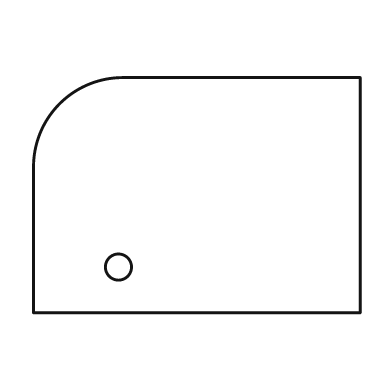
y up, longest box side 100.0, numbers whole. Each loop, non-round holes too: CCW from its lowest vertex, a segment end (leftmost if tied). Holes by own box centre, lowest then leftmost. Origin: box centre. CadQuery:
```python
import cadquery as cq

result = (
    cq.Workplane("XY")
    .moveTo(-50.0, -36.0)
    .lineTo(50.0, -36.0)
    .lineTo(50.0, 36.0)
    .lineTo(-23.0, 36.0)
    .threePointArc((-42.0, 28.0), (-50.0, 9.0))
    .close()
    .moveTo(-24.0, -22.0)
    .circle(4.0)
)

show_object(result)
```